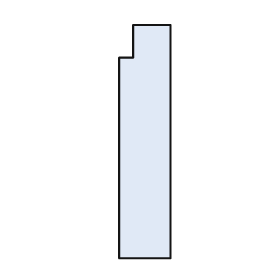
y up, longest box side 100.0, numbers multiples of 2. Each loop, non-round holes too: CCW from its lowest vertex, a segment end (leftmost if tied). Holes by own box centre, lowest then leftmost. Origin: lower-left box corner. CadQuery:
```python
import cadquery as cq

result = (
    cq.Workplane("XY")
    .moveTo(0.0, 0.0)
    .lineTo(22.0, 0.0)
    .lineTo(22.0, 100.0)
    .lineTo(6.0, 100.0)
    .lineTo(6.0, 86.0)
    .lineTo(0.0, 86.0)
    .close()
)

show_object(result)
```